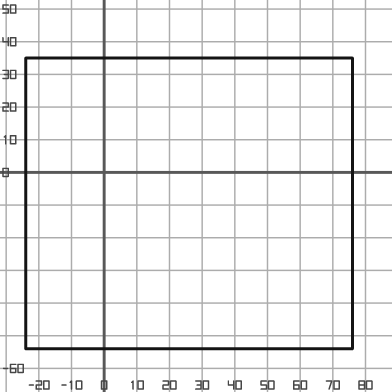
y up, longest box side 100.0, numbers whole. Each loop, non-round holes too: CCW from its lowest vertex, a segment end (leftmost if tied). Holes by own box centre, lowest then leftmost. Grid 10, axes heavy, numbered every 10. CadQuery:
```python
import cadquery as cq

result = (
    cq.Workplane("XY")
    .moveTo(-24.0, -54.0)
    .lineTo(76.0, -54.0)
    .lineTo(76.0, 35.0)
    .lineTo(-24.0, 35.0)
    .close()
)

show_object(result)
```